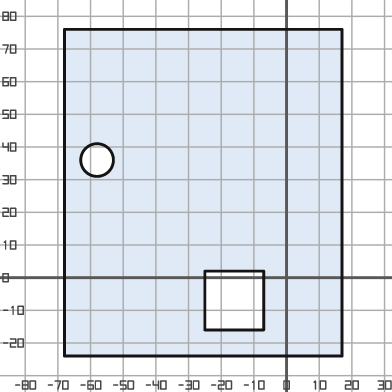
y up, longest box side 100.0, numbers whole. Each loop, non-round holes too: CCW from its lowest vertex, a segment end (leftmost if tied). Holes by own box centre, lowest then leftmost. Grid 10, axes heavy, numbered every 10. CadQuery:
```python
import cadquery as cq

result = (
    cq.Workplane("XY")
    .moveTo(-68.0, -24.0)
    .lineTo(17.0, -24.0)
    .lineTo(17.0, 76.0)
    .lineTo(-68.0, 76.0)
    .close()
    .moveTo(-25.0, -16.0)
    .lineTo(-7.0, -16.0)
    .lineTo(-7.0, 2.0)
    .lineTo(-25.0, 2.0)
    .close()
    .moveTo(-58.0, 36.0)
    .circle(5.0)
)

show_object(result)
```